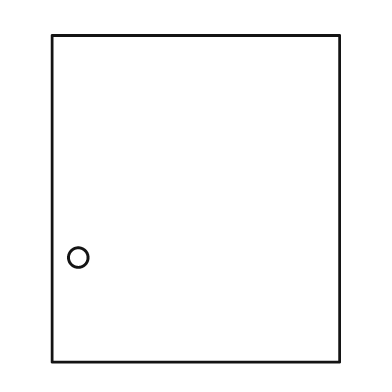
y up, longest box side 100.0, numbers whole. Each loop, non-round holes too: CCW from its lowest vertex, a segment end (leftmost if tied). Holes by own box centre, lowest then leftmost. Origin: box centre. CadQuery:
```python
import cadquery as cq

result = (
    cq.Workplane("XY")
    .moveTo(-44.0, -50.0)
    .lineTo(44.0, -50.0)
    .lineTo(44.0, 50.0)
    .lineTo(-44.0, 50.0)
    .close()
    .moveTo(-36.0, -18.0)
    .circle(3.0)
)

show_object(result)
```